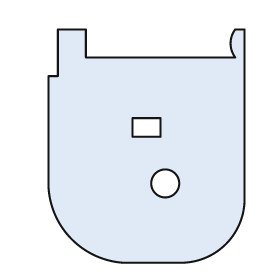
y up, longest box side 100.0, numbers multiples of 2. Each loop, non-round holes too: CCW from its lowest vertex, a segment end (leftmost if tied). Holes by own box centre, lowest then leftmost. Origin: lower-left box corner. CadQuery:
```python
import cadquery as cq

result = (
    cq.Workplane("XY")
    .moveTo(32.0, 0.0)
    .lineTo(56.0, 0.0)
    .threePointArc((76.0, 8.0), (84.0, 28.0))
    .lineTo(84.0, 100.0)
    .lineTo(80.0, 100.0)
    .threePointArc((78.0, 94.0), (80.0, 88.0))
    .lineTo(16.0, 88.0)
    .lineTo(16.0, 100.0)
    .lineTo(4.0, 100.0)
    .lineTo(4.0, 80.0)
    .lineTo(0.0, 80.0)
    .lineTo(0.0, 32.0)
    .threePointArc((10.0, 10.0), (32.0, 0.0))
    .close()
    .moveTo(50.0, 34.0)
    .circle(6.0)
    .moveTo(36.0, 54.0)
    .lineTo(48.0, 54.0)
    .lineTo(48.0, 62.0)
    .lineTo(36.0, 62.0)
    .close()
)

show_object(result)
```